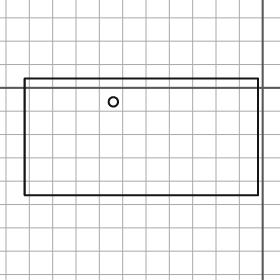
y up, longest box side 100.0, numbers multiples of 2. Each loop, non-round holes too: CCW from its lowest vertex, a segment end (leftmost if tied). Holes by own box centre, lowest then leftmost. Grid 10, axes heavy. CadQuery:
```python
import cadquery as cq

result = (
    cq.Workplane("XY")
    .moveTo(-102.0, -46.0)
    .lineTo(-2.0, -46.0)
    .lineTo(-2.0, 4.0)
    .lineTo(-102.0, 4.0)
    .close()
    .moveTo(-64.0, -6.0)
    .circle(2.0)
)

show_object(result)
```